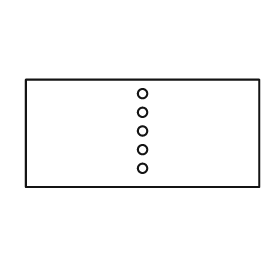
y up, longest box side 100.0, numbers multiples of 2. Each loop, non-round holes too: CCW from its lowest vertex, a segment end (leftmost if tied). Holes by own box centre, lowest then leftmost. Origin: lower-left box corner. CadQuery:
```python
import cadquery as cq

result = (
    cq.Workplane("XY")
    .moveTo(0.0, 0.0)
    .lineTo(100.0, 0.0)
    .lineTo(100.0, 46.0)
    .lineTo(0.0, 46.0)
    .close()
    .moveTo(50.0, 8.0)
    .circle(2.0)
    .moveTo(50.0, 16.0)
    .circle(2.0)
    .moveTo(50.0, 24.0)
    .circle(2.0)
    .moveTo(50.0, 32.0)
    .circle(2.0)
    .moveTo(50.0, 40.0)
    .circle(2.0)
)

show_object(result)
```